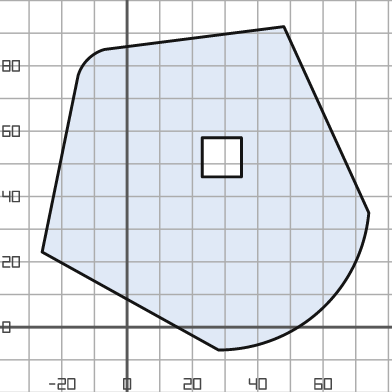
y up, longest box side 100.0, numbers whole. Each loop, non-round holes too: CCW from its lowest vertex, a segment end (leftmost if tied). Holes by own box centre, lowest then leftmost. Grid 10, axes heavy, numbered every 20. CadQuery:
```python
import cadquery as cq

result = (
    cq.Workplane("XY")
    .moveTo(28.0, -7.0)
    .threePointArc((59.0, 5.0), (74.0, 35.0))
    .lineTo(48.0, 92.0)
    .lineTo(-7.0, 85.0)
    .threePointArc((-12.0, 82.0), (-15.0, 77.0))
    .lineTo(-26.0, 23.0)
    .close()
    .moveTo(23.0, 46.0)
    .lineTo(35.0, 46.0)
    .lineTo(35.0, 58.0)
    .lineTo(23.0, 58.0)
    .close()
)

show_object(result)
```